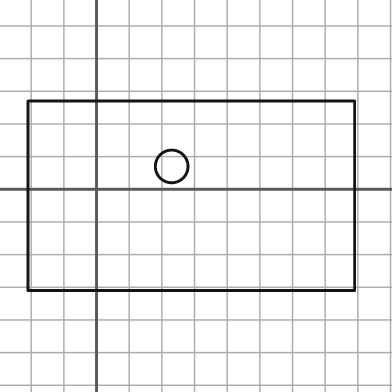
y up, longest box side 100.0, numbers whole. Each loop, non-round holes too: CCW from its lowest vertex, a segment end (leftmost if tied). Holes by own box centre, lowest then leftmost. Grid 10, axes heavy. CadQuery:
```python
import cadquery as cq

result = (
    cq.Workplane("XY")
    .moveTo(-21.0, -31.0)
    .lineTo(79.0, -31.0)
    .lineTo(79.0, 27.0)
    .lineTo(-21.0, 27.0)
    .close()
    .moveTo(23.0, 7.0)
    .circle(5.0)
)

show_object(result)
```